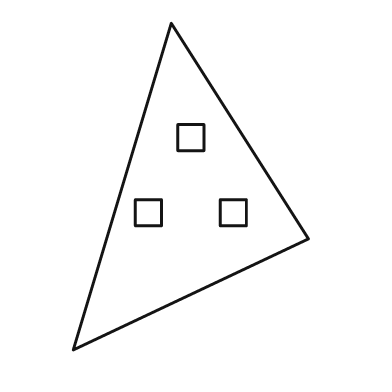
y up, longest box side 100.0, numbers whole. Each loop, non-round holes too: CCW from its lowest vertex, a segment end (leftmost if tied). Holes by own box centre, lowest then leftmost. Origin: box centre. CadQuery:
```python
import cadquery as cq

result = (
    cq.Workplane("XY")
    .moveTo(-36.0, -50.0)
    .lineTo(36.0, -16.0)
    .lineTo(-6.0, 50.0)
    .close()
    .moveTo(-17.0, -12.0)
    .lineTo(-9.0, -12.0)
    .lineTo(-9.0, -4.0)
    .lineTo(-17.0, -4.0)
    .close()
    .moveTo(9.0, -12.0)
    .lineTo(17.0, -12.0)
    .lineTo(17.0, -4.0)
    .lineTo(9.0, -4.0)
    .close()
    .moveTo(-4.0, 11.0)
    .lineTo(4.0, 11.0)
    .lineTo(4.0, 19.0)
    .lineTo(-4.0, 19.0)
    .close()
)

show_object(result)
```